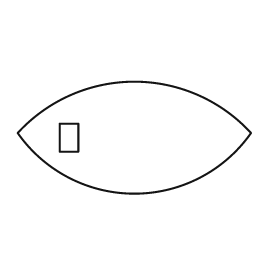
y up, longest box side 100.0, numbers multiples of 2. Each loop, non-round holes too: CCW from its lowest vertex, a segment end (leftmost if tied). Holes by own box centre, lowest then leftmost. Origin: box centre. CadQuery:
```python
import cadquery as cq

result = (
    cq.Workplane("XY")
    .moveTo(-50.0, 2.0)
    .threePointArc((0.0, -24.0), (50.0, 2.0))
    .threePointArc((0.0, 24.0), (-50.0, 2.0))
    .close()
    .moveTo(-32.0, -6.0)
    .lineTo(-24.0, -6.0)
    .lineTo(-24.0, 6.0)
    .lineTo(-32.0, 6.0)
    .close()
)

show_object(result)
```